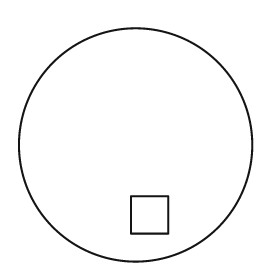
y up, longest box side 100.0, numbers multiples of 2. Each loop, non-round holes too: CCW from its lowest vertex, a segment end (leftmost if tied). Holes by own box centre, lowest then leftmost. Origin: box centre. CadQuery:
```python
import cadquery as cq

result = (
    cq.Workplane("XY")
    .moveTo(0.0, 0.0)
    .circle(50.0)
    .moveTo(-2.0, -38.0)
    .lineTo(14.0, -38.0)
    .lineTo(14.0, -22.0)
    .lineTo(-2.0, -22.0)
    .close()
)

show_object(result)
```